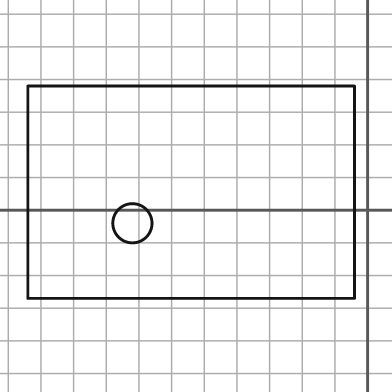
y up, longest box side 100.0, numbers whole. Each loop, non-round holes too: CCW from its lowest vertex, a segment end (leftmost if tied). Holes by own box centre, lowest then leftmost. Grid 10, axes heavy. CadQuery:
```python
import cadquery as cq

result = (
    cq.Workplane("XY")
    .moveTo(-104.0, -27.0)
    .lineTo(-4.0, -27.0)
    .lineTo(-4.0, 38.0)
    .lineTo(-104.0, 38.0)
    .close()
    .moveTo(-72.0, -4.0)
    .circle(6.0)
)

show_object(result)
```